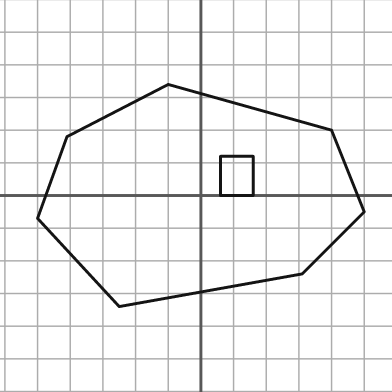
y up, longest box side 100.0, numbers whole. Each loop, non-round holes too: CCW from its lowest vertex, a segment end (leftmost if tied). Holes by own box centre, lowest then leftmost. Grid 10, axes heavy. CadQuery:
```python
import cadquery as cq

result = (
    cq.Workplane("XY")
    .moveTo(-25.0, -34.0)
    .lineTo(31.0, -24.0)
    .lineTo(50.0, -5.0)
    .lineTo(40.0, 20.0)
    .lineTo(-10.0, 34.0)
    .lineTo(-41.0, 18.0)
    .lineTo(-50.0, -7.0)
    .close()
    .moveTo(6.0, 0.0)
    .lineTo(16.0, 0.0)
    .lineTo(16.0, 12.0)
    .lineTo(6.0, 12.0)
    .close()
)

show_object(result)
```